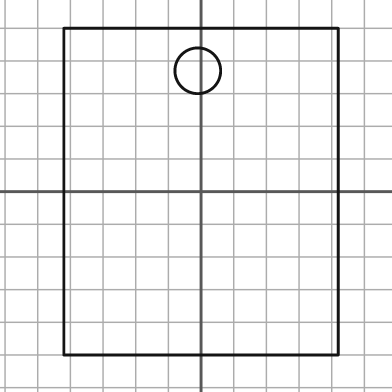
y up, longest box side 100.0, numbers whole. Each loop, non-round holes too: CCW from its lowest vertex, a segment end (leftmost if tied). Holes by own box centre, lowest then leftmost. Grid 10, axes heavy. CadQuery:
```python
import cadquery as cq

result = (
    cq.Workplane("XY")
    .moveTo(-42.0, -50.0)
    .lineTo(42.0, -50.0)
    .lineTo(42.0, 50.0)
    .lineTo(-42.0, 50.0)
    .close()
    .moveTo(-1.0, 37.0)
    .circle(7.0)
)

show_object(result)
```